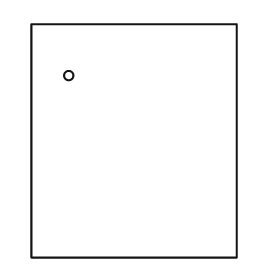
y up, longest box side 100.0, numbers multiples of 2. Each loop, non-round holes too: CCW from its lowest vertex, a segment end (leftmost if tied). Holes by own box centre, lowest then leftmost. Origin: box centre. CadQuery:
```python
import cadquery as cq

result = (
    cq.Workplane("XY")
    .moveTo(-44.0, -50.0)
    .lineTo(44.0, -50.0)
    .lineTo(44.0, 50.0)
    .lineTo(-44.0, 50.0)
    .close()
    .moveTo(-28.0, 28.0)
    .circle(2.0)
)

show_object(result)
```